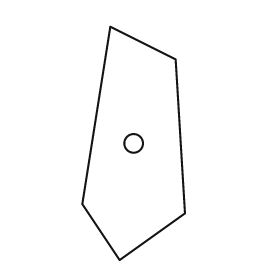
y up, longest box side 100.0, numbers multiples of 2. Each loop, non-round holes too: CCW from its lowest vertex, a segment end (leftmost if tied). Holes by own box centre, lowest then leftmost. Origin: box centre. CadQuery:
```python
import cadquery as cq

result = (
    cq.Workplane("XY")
    .moveTo(-6.0, -50.0)
    .lineTo(22.0, -30.0)
    .lineTo(18.0, 36.0)
    .lineTo(-10.0, 50.0)
    .lineTo(-22.0, -26.0)
    .close()
    .moveTo(0.0, 0.0)
    .circle(4.0)
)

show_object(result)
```